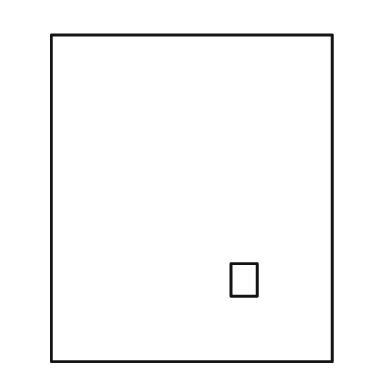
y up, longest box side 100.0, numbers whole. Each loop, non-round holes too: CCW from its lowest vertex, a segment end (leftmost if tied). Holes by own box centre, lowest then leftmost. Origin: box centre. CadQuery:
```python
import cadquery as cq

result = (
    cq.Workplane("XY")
    .moveTo(-43.0, -50.0)
    .lineTo(43.0, -50.0)
    .lineTo(43.0, 50.0)
    .lineTo(-43.0, 50.0)
    .close()
    .moveTo(12.0, -30.0)
    .lineTo(20.0, -30.0)
    .lineTo(20.0, -20.0)
    .lineTo(12.0, -20.0)
    .close()
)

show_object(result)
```